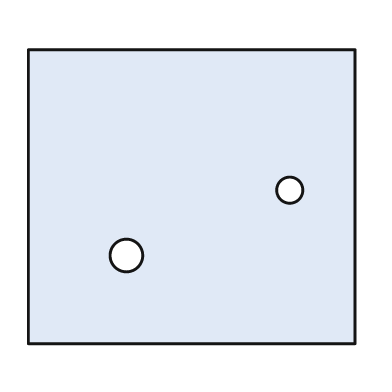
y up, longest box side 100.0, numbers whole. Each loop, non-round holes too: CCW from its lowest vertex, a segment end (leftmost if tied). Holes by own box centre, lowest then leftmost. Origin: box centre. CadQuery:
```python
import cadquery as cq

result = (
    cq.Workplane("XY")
    .moveTo(-50.0, -45.0)
    .lineTo(50.0, -45.0)
    .lineTo(50.0, 45.0)
    .lineTo(-50.0, 45.0)
    .close()
    .moveTo(-20.0, -18.0)
    .circle(5.0)
    .moveTo(30.0, 2.0)
    .circle(4.0)
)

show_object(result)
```